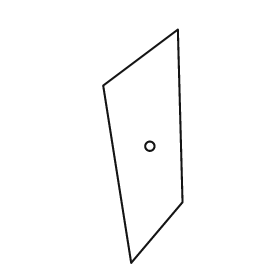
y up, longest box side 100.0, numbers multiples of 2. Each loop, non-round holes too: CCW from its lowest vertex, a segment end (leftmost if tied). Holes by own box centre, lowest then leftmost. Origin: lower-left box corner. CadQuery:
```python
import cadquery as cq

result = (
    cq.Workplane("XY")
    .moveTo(12.0, 0.0)
    .lineTo(34.0, 26.0)
    .lineTo(32.0, 100.0)
    .lineTo(0.0, 76.0)
    .close()
    .moveTo(20.0, 50.0)
    .circle(2.0)
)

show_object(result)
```